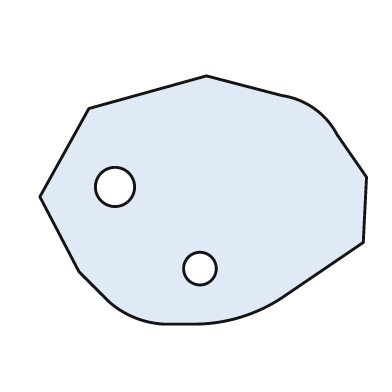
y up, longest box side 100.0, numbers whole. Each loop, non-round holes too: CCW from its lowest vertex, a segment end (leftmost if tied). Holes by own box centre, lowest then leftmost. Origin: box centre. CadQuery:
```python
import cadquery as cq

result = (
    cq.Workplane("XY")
    .moveTo(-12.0, -38.0)
    .lineTo(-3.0, -38.0)
    .threePointArc((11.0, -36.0), (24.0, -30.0))
    .lineTo(49.0, -13.0)
    .lineTo(50.0, 7.0)
    .lineTo(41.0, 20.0)
    .threePointArc((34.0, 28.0), (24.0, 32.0))
    .lineTo(1.0, 38.0)
    .lineTo(-35.0, 28.0)
    .lineTo(-50.0, 1.0)
    .lineTo(-38.0, -22.0)
    .lineTo(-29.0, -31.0)
    .threePointArc((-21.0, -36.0), (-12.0, -38.0))
    .close()
    .moveTo(-1.0, -21.0)
    .circle(5.0)
    .moveTo(-27.0, 4.0)
    .circle(6.0)
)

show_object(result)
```